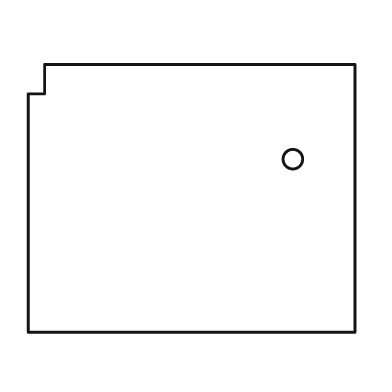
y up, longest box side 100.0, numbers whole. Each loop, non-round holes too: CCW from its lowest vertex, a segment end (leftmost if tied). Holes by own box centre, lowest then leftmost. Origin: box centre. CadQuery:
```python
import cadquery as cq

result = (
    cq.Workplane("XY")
    .moveTo(-50.0, -41.0)
    .lineTo(50.0, -41.0)
    .lineTo(50.0, 41.0)
    .lineTo(-45.0, 41.0)
    .lineTo(-45.0, 32.0)
    .lineTo(-50.0, 32.0)
    .close()
    .moveTo(31.0, 12.0)
    .circle(3.0)
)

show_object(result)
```